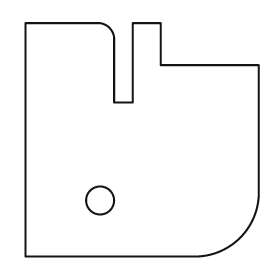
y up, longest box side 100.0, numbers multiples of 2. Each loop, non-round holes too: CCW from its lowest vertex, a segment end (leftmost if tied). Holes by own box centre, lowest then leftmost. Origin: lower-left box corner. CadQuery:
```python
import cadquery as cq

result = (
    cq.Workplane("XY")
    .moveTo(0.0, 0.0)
    .lineTo(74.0, 0.0)
    .threePointArc((92.0, 8.0), (100.0, 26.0))
    .lineTo(100.0, 82.0)
    .lineTo(58.0, 82.0)
    .lineTo(58.0, 100.0)
    .lineTo(46.0, 100.0)
    .lineTo(46.0, 66.0)
    .lineTo(38.0, 66.0)
    .lineTo(38.0, 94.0)
    .threePointArc((36.0, 98.0), (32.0, 100.0))
    .lineTo(0.0, 100.0)
    .close()
    .moveTo(32.0, 24.0)
    .circle(6.0)
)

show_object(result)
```